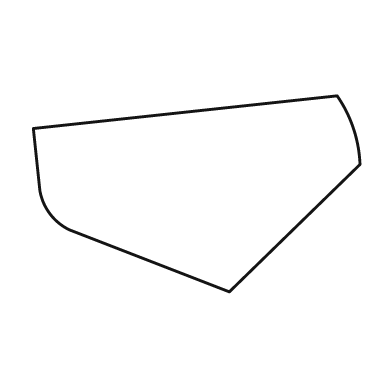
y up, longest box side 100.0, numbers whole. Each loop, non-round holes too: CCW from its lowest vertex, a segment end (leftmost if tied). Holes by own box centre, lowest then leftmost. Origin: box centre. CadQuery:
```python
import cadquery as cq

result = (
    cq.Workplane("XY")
    .moveTo(10.0, -30.0)
    .lineTo(50.0, 9.0)
    .threePointArc((48.0, 20.0), (43.0, 30.0))
    .lineTo(-50.0, 20.0)
    .lineTo(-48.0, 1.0)
    .threePointArc((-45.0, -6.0), (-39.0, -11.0))
    .close()
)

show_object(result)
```